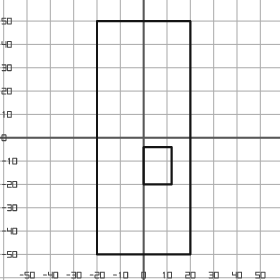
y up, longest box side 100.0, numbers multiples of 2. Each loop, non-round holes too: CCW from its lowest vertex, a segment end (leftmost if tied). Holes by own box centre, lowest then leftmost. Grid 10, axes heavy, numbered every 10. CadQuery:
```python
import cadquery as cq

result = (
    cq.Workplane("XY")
    .moveTo(-20.0, -50.0)
    .lineTo(20.0, -50.0)
    .lineTo(20.0, 50.0)
    .lineTo(-20.0, 50.0)
    .close()
    .moveTo(0.0, -20.0)
    .lineTo(12.0, -20.0)
    .lineTo(12.0, -4.0)
    .lineTo(0.0, -4.0)
    .close()
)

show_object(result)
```